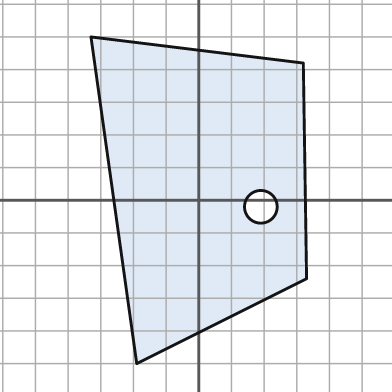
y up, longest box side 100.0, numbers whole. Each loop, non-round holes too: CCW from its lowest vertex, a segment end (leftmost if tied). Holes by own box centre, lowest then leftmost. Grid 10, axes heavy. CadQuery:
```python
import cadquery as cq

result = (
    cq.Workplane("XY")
    .moveTo(-19.0, -50.0)
    .lineTo(33.0, -24.0)
    .lineTo(32.0, 42.0)
    .lineTo(-33.0, 50.0)
    .close()
    .moveTo(19.0, -2.0)
    .circle(5.0)
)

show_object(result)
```